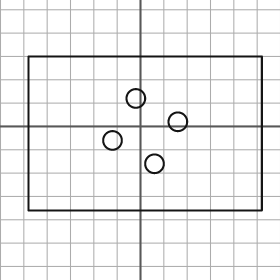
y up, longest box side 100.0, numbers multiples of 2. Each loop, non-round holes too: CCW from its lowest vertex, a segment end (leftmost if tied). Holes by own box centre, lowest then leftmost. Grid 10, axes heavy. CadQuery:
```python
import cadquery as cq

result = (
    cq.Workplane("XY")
    .moveTo(-48.0, -36.0)
    .lineTo(52.0, -36.0)
    .lineTo(52.0, 30.0)
    .lineTo(-48.0, 30.0)
    .close()
    .moveTo(6.0, -16.0)
    .circle(4.0)
    .moveTo(-12.0, -6.0)
    .circle(4.0)
    .moveTo(16.0, 2.0)
    .circle(4.0)
    .moveTo(-2.0, 12.0)
    .circle(4.0)
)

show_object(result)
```